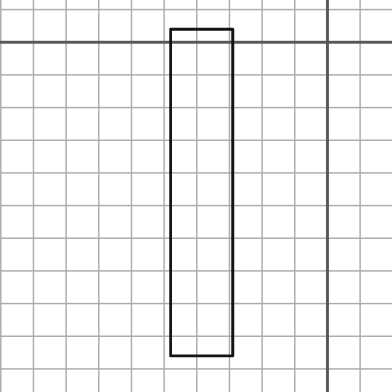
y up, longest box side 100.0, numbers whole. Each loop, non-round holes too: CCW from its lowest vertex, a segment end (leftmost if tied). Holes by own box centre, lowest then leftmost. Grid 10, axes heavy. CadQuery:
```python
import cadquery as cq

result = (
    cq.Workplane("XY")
    .moveTo(-48.0, -96.0)
    .lineTo(-29.0, -96.0)
    .lineTo(-29.0, 4.0)
    .lineTo(-48.0, 4.0)
    .close()
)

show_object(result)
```